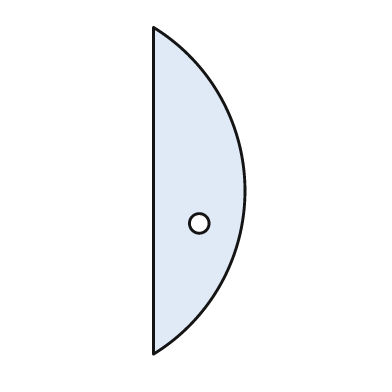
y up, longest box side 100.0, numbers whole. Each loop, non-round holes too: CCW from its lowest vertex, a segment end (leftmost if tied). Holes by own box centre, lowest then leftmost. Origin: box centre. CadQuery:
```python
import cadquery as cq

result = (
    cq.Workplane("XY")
    .moveTo(-14.0, -50.0)
    .threePointArc((14.0, 0.0), (-14.0, 50.0))
    .close()
    .moveTo(0.0, -10.0)
    .circle(3.0)
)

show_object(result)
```